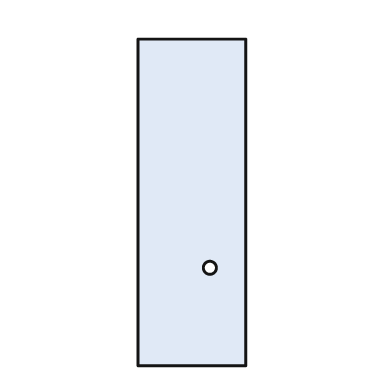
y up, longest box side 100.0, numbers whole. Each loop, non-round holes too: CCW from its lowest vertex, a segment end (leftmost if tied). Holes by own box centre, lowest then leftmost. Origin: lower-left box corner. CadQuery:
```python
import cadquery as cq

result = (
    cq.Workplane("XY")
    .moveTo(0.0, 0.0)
    .lineTo(33.0, 0.0)
    .lineTo(33.0, 100.0)
    .lineTo(0.0, 100.0)
    .close()
    .moveTo(22.0, 30.0)
    .circle(2.0)
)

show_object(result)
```